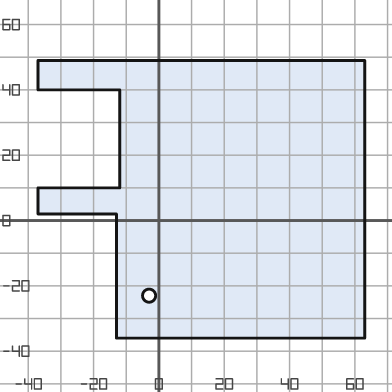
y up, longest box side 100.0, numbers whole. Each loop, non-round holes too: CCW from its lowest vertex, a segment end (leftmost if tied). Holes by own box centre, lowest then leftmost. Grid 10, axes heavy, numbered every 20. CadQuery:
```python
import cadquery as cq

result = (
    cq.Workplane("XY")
    .moveTo(-13.0, -36.0)
    .lineTo(63.0, -36.0)
    .lineTo(63.0, 49.0)
    .lineTo(-37.0, 49.0)
    .lineTo(-37.0, 40.0)
    .lineTo(-12.0, 40.0)
    .lineTo(-12.0, 10.0)
    .lineTo(-37.0, 10.0)
    .lineTo(-37.0, 2.0)
    .lineTo(-13.0, 2.0)
    .close()
    .moveTo(-3.0, -23.0)
    .circle(2.0)
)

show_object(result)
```